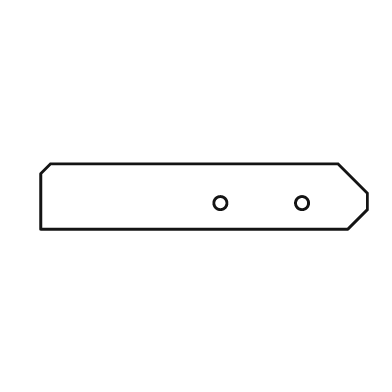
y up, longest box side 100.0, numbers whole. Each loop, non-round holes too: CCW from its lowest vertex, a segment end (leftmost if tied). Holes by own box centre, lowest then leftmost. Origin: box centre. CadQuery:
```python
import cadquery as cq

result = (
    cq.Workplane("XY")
    .moveTo(-50.0, -10.0)
    .lineTo(44.0, -10.0)
    .lineTo(50.0, -4.0)
    .lineTo(50.0, 1.0)
    .lineTo(41.0, 10.0)
    .lineTo(-47.0, 10.0)
    .lineTo(-50.0, 7.0)
    .close()
    .moveTo(5.0, -2.0)
    .circle(2.0)
    .moveTo(30.0, -2.0)
    .circle(2.0)
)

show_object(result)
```